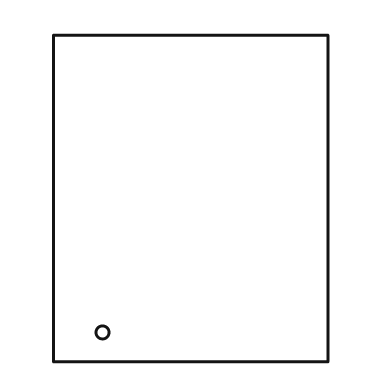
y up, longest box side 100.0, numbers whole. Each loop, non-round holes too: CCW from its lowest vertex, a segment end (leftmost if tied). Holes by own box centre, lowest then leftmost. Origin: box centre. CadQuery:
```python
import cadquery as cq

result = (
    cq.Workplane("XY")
    .moveTo(-42.0, -50.0)
    .lineTo(42.0, -50.0)
    .lineTo(42.0, 50.0)
    .lineTo(-42.0, 50.0)
    .close()
    .moveTo(-27.0, -41.0)
    .circle(2.0)
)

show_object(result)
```